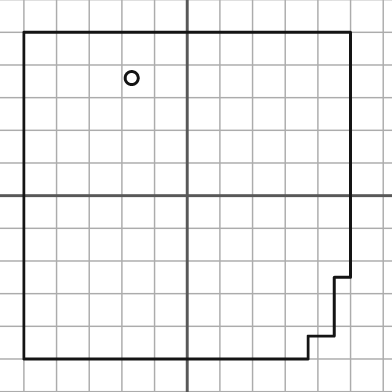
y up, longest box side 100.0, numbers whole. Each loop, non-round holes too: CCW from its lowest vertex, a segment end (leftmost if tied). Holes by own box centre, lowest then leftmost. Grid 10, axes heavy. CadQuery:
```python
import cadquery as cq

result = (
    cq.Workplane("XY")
    .moveTo(-50.0, -50.0)
    .lineTo(37.0, -50.0)
    .lineTo(37.0, -43.0)
    .lineTo(45.0, -43.0)
    .lineTo(45.0, -25.0)
    .lineTo(50.0, -25.0)
    .lineTo(50.0, 50.0)
    .lineTo(-50.0, 50.0)
    .close()
    .moveTo(-17.0, 36.0)
    .circle(2.0)
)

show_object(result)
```